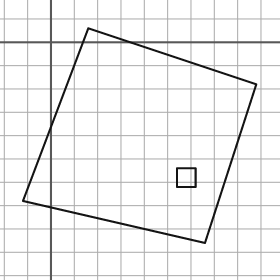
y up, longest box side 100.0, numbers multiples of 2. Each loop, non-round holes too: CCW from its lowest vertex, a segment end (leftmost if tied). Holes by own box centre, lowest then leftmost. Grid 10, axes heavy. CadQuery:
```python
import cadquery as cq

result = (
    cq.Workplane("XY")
    .moveTo(66.0, -86.0)
    .lineTo(88.0, -18.0)
    .lineTo(16.0, 6.0)
    .lineTo(-12.0, -68.0)
    .close()
    .moveTo(54.0, -62.0)
    .lineTo(62.0, -62.0)
    .lineTo(62.0, -54.0)
    .lineTo(54.0, -54.0)
    .close()
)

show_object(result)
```